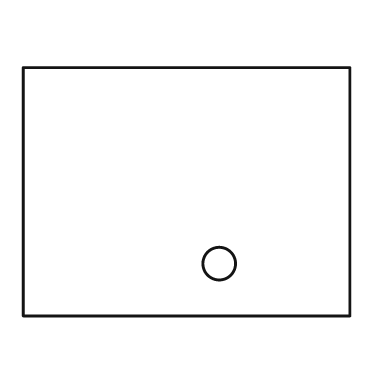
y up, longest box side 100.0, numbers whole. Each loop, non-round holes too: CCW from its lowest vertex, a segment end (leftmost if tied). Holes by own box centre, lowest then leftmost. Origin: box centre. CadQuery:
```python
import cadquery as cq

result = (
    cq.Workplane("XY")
    .moveTo(-50.0, -38.0)
    .lineTo(50.0, -38.0)
    .lineTo(50.0, 38.0)
    .lineTo(-50.0, 38.0)
    .close()
    .moveTo(10.0, -22.0)
    .circle(5.0)
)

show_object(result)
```